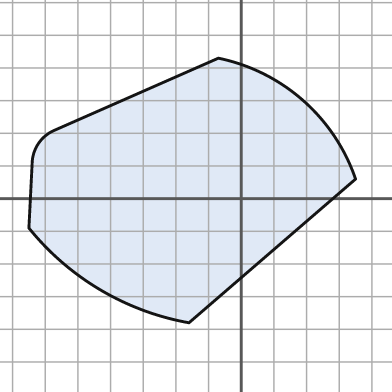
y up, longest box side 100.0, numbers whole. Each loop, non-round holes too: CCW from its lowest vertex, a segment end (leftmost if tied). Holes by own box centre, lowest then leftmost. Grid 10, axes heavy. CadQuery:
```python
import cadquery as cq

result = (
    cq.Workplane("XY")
    .moveTo(-16.0, -38.0)
    .lineTo(35.0, 6.0)
    .threePointArc((19.0, 30.0), (-7.0, 43.0))
    .lineTo(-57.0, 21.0)
    .threePointArc((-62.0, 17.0), (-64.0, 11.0))
    .lineTo(-65.0, -9.0)
    .threePointArc((-43.0, -28.0), (-16.0, -38.0))
    .close()
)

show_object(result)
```